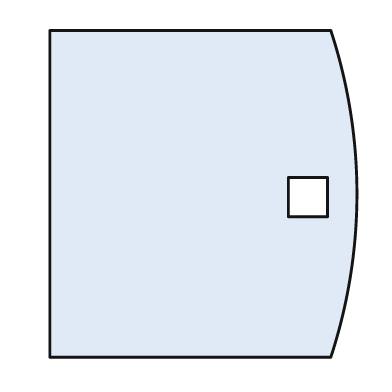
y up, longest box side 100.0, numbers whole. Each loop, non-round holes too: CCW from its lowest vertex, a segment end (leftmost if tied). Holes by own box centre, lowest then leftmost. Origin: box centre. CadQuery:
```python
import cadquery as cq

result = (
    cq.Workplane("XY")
    .moveTo(-47.0, -50.0)
    .lineTo(39.0, -50.0)
    .threePointArc((47.0, 0.0), (39.0, 50.0))
    .lineTo(-47.0, 50.0)
    .close()
    .moveTo(26.0, -7.0)
    .lineTo(38.0, -7.0)
    .lineTo(38.0, 5.0)
    .lineTo(26.0, 5.0)
    .close()
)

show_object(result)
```